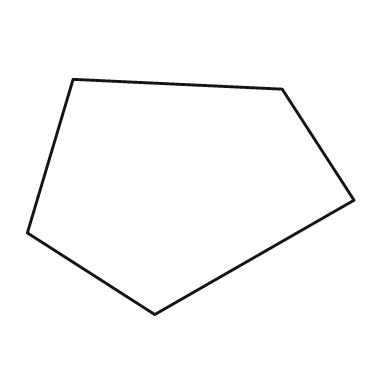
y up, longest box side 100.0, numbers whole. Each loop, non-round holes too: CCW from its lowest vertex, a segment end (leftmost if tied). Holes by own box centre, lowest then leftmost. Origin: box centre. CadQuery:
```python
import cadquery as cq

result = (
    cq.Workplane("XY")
    .moveTo(-11.0, -36.0)
    .lineTo(50.0, -1.0)
    .lineTo(28.0, 33.0)
    .lineTo(-36.0, 36.0)
    .lineTo(-50.0, -11.0)
    .close()
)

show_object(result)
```